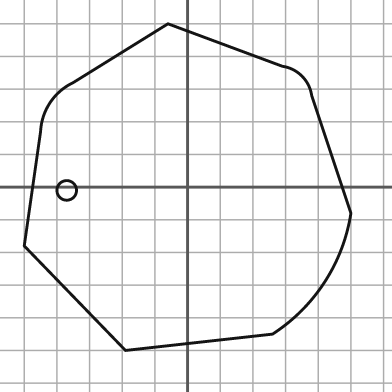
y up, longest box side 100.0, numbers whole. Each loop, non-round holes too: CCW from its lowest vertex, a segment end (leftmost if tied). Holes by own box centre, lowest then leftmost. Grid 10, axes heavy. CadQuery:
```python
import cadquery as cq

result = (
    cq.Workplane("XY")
    .moveTo(-19.0, -50.0)
    .lineTo(26.0, -45.0)
    .threePointArc((42.0, -29.0), (50.0, -8.0))
    .lineTo(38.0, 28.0)
    .threePointArc((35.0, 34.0), (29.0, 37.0))
    .lineTo(-6.0, 50.0)
    .lineTo(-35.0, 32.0)
    .threePointArc((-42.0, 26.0), (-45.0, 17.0))
    .lineTo(-50.0, -18.0)
    .close()
    .moveTo(-37.0, -1.0)
    .circle(3.0)
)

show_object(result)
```